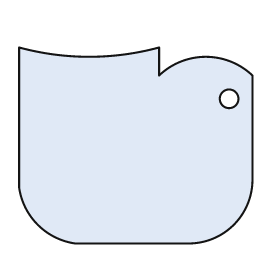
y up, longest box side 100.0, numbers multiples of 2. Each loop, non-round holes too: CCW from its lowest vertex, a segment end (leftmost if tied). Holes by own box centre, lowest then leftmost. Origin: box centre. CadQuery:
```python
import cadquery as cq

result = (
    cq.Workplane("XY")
    .moveTo(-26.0, -42.0)
    .lineTo(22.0, -42.0)
    .threePointArc((42.0, -34.0), (50.0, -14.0))
    .lineTo(50.0, 30.0)
    .threePointArc((30.0, 38.0), (10.0, 30.0))
    .lineTo(10.0, 42.0)
    .threePointArc((-20.0, 38.0), (-50.0, 42.0))
    .lineTo(-50.0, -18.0)
    .threePointArc((-42.0, -34.0), (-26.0, -42.0))
    .close()
    .moveTo(40.0, 20.0)
    .circle(4.0)
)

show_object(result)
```